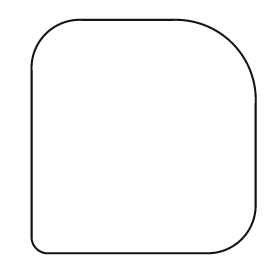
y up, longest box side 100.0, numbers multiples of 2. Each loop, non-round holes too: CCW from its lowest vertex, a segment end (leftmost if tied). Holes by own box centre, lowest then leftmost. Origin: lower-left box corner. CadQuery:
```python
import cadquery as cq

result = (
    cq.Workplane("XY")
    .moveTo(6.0, 0.0)
    .lineTo(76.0, 0.0)
    .threePointArc((90.0, 6.0), (96.0, 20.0))
    .lineTo(96.0, 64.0)
    .threePointArc((86.0, 90.0), (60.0, 100.0))
    .lineTo(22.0, 100.0)
    .threePointArc((6.0, 94.0), (0.0, 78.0))
    .lineTo(0.0, 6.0)
    .threePointArc((2.0, 2.0), (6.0, 0.0))
    .close()
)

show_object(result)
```